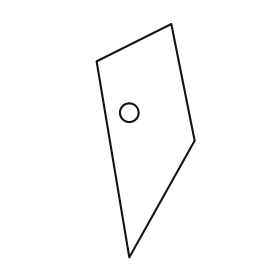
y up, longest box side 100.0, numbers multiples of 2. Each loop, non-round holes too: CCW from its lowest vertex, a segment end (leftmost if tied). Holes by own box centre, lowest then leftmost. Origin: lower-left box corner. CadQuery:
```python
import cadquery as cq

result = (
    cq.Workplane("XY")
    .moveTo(14.0, 0.0)
    .lineTo(42.0, 50.0)
    .lineTo(32.0, 100.0)
    .lineTo(0.0, 84.0)
    .close()
    .moveTo(14.0, 62.0)
    .circle(4.0)
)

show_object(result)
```